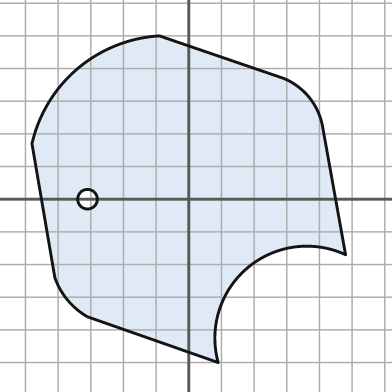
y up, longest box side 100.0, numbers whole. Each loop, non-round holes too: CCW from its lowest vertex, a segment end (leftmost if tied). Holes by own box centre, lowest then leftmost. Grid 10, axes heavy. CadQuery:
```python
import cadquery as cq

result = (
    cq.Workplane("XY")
    .moveTo(9.0, -50.0)
    .threePointArc((18.0, -21.0), (48.0, -17.0))
    .lineTo(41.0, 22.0)
    .threePointArc((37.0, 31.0), (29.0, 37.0))
    .lineTo(-9.0, 50.0)
    .threePointArc((-34.0, 40.0), (-48.0, 17.0))
    .lineTo(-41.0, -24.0)
    .threePointArc((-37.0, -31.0), (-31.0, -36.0))
    .close()
    .moveTo(-31.0, 0.0)
    .circle(3.0)
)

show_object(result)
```